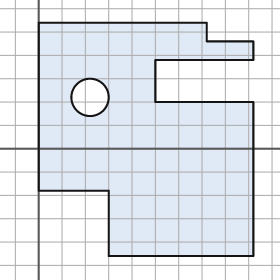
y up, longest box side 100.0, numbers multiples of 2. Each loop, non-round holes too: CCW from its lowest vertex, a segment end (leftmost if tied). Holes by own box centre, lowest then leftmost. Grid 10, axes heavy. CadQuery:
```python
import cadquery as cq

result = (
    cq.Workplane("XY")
    .moveTo(30.0, -46.0)
    .lineTo(92.0, -46.0)
    .lineTo(92.0, 20.0)
    .lineTo(50.0, 20.0)
    .lineTo(50.0, 38.0)
    .lineTo(92.0, 38.0)
    .lineTo(92.0, 46.0)
    .lineTo(72.0, 46.0)
    .lineTo(72.0, 54.0)
    .lineTo(0.0, 54.0)
    .lineTo(0.0, -18.0)
    .lineTo(30.0, -18.0)
    .close()
    .moveTo(22.0, 22.0)
    .circle(8.0)
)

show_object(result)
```